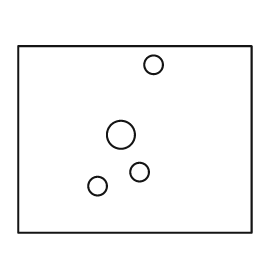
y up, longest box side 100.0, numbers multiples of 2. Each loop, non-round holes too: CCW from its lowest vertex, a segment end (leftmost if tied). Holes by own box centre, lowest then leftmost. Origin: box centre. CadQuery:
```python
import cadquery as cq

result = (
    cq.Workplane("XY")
    .moveTo(-50.0, -40.0)
    .lineTo(50.0, -40.0)
    .lineTo(50.0, 40.0)
    .lineTo(-50.0, 40.0)
    .close()
    .moveTo(-16.0, -20.0)
    .circle(4.0)
    .moveTo(2.0, -14.0)
    .circle(4.0)
    .moveTo(-6.0, 2.0)
    .circle(6.0)
    .moveTo(8.0, 32.0)
    .circle(4.0)
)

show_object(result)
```